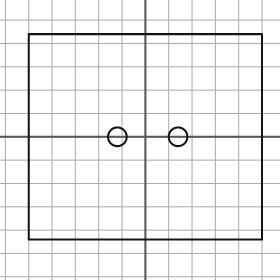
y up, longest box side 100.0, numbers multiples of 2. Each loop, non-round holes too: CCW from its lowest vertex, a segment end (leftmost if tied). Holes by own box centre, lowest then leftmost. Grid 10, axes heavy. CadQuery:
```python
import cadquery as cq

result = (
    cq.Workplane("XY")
    .moveTo(-50.0, -44.0)
    .lineTo(50.0, -44.0)
    .lineTo(50.0, 44.0)
    .lineTo(-50.0, 44.0)
    .close()
    .moveTo(-12.0, 0.0)
    .circle(4.0)
    .moveTo(14.0, 0.0)
    .circle(4.0)
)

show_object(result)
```